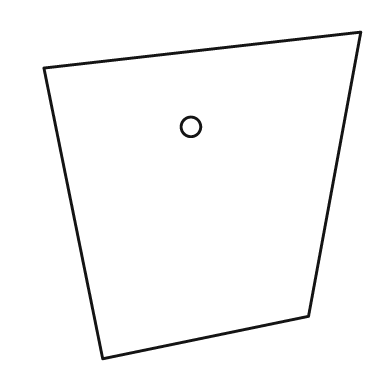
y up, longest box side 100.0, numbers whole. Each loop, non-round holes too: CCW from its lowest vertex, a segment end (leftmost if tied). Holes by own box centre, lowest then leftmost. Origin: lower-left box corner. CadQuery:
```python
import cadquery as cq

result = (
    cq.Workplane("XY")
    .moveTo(18.0, 0.0)
    .lineTo(81.0, 13.0)
    .lineTo(97.0, 100.0)
    .lineTo(0.0, 89.0)
    .close()
    .moveTo(45.0, 71.0)
    .circle(3.0)
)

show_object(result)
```